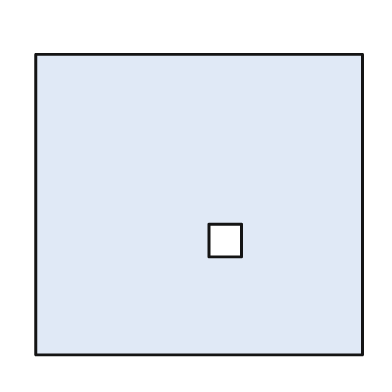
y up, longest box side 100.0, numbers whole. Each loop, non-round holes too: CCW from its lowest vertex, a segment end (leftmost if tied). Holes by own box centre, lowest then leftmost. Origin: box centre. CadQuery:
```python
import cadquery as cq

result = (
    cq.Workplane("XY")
    .moveTo(-50.0, -46.0)
    .lineTo(50.0, -46.0)
    .lineTo(50.0, 46.0)
    .lineTo(-50.0, 46.0)
    .close()
    .moveTo(3.0, -16.0)
    .lineTo(13.0, -16.0)
    .lineTo(13.0, -6.0)
    .lineTo(3.0, -6.0)
    .close()
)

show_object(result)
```